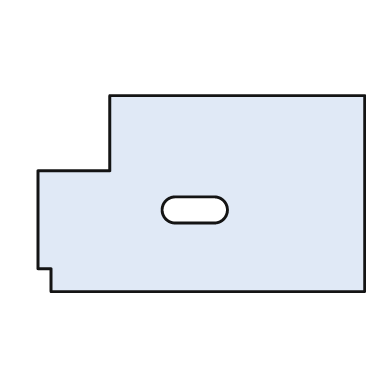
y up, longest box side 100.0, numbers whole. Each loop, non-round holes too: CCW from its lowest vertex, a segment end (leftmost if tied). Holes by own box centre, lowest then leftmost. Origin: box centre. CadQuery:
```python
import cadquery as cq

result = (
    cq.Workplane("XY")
    .moveTo(-46.0, -30.0)
    .lineTo(50.0, -30.0)
    .lineTo(50.0, 30.0)
    .lineTo(-28.0, 30.0)
    .lineTo(-28.0, 7.0)
    .lineTo(-50.0, 7.0)
    .lineTo(-50.0, -23.0)
    .lineTo(-46.0, -23.0)
    .close()
    .moveTo(-8.0, -9.0)
    .lineTo(4.0, -9.0)
    .threePointArc((8.0, -5.0), (4.0, -1.0))
    .lineTo(-8.0, -1.0)
    .threePointArc((-12.0, -5.0), (-8.0, -9.0))
    .close()
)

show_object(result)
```